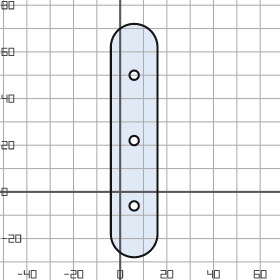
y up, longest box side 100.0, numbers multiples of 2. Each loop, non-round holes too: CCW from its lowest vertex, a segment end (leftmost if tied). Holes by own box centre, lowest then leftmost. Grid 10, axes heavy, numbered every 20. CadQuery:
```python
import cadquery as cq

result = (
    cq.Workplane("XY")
    .moveTo(-4.0, -18.0)
    .threePointArc((6.0, -28.0), (16.0, -18.0))
    .lineTo(16.0, 62.0)
    .threePointArc((6.0, 72.0), (-4.0, 62.0))
    .close()
    .moveTo(6.0, -6.0)
    .circle(2.0)
    .moveTo(6.0, 22.0)
    .circle(2.0)
    .moveTo(6.0, 50.0)
    .circle(2.0)
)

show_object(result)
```